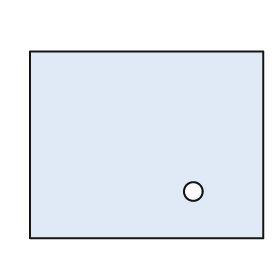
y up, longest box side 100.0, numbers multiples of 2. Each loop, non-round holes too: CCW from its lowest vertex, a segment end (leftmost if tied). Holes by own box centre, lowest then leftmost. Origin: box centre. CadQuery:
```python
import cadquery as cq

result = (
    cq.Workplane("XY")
    .moveTo(-50.0, -40.0)
    .lineTo(50.0, -40.0)
    .lineTo(50.0, 40.0)
    .lineTo(-50.0, 40.0)
    .close()
    .moveTo(20.0, -20.0)
    .circle(4.0)
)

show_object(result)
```